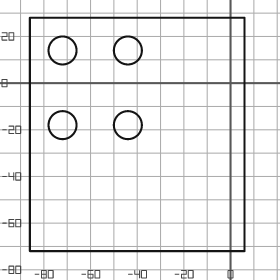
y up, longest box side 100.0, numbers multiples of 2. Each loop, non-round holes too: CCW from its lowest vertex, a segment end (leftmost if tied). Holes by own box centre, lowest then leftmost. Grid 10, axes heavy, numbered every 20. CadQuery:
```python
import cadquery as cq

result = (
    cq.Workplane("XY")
    .moveTo(-86.0, -72.0)
    .lineTo(6.0, -72.0)
    .lineTo(6.0, 28.0)
    .lineTo(-86.0, 28.0)
    .close()
    .moveTo(-72.0, -18.0)
    .circle(6.0)
    .moveTo(-44.0, -18.0)
    .circle(6.0)
    .moveTo(-72.0, 14.0)
    .circle(6.0)
    .moveTo(-44.0, 14.0)
    .circle(6.0)
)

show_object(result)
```